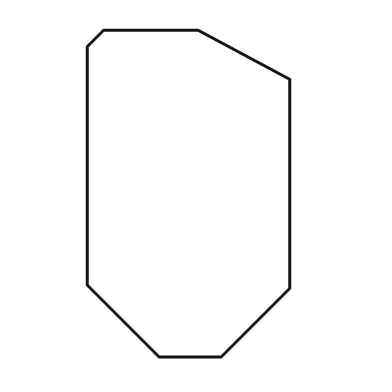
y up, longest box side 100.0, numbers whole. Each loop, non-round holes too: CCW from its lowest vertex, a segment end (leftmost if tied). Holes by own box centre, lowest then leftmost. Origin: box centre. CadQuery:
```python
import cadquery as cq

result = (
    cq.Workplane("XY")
    .moveTo(-9.0, -50.0)
    .lineTo(10.0, -50.0)
    .lineTo(31.0, -29.0)
    .lineTo(31.0, 35.0)
    .lineTo(3.0, 50.0)
    .lineTo(-26.0, 50.0)
    .lineTo(-31.0, 45.0)
    .lineTo(-31.0, -28.0)
    .close()
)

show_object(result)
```